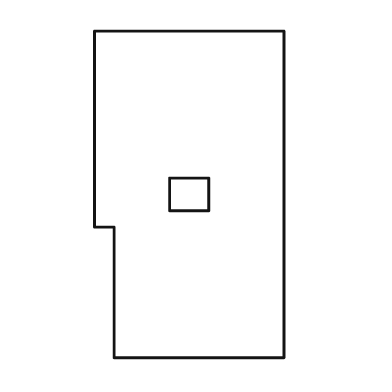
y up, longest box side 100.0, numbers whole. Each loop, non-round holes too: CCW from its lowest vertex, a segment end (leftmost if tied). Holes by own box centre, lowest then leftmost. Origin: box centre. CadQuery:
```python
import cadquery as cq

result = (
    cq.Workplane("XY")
    .moveTo(-23.0, -50.0)
    .lineTo(29.0, -50.0)
    .lineTo(29.0, 50.0)
    .lineTo(-29.0, 50.0)
    .lineTo(-29.0, -10.0)
    .lineTo(-23.0, -10.0)
    .close()
    .moveTo(-6.0, -5.0)
    .lineTo(6.0, -5.0)
    .lineTo(6.0, 5.0)
    .lineTo(-6.0, 5.0)
    .close()
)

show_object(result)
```